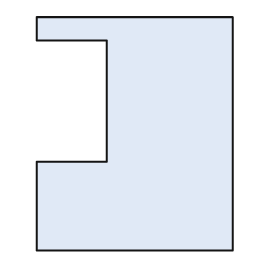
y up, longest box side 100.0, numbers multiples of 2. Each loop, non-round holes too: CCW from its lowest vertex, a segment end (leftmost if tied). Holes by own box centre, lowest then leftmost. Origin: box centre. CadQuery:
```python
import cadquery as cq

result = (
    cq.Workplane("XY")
    .moveTo(-42.0, -50.0)
    .lineTo(42.0, -50.0)
    .lineTo(42.0, 50.0)
    .lineTo(-42.0, 50.0)
    .lineTo(-42.0, 40.0)
    .lineTo(-12.0, 40.0)
    .lineTo(-12.0, -12.0)
    .lineTo(-42.0, -12.0)
    .close()
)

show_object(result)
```